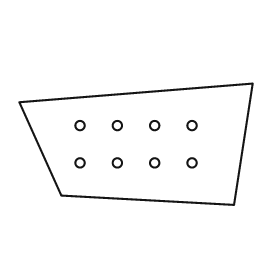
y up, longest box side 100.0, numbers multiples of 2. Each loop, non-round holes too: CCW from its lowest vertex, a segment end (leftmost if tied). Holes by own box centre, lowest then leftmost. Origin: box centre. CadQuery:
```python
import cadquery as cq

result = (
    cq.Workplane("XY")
    .moveTo(42.0, -26.0)
    .lineTo(50.0, 26.0)
    .lineTo(-50.0, 18.0)
    .lineTo(-32.0, -22.0)
    .close()
    .moveTo(-24.0, -8.0)
    .circle(2.0)
    .moveTo(-8.0, -8.0)
    .circle(2.0)
    .moveTo(8.0, -8.0)
    .circle(2.0)
    .moveTo(24.0, -8.0)
    .circle(2.0)
    .moveTo(-24.0, 8.0)
    .circle(2.0)
    .moveTo(-8.0, 8.0)
    .circle(2.0)
    .moveTo(8.0, 8.0)
    .circle(2.0)
    .moveTo(24.0, 8.0)
    .circle(2.0)
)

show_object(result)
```